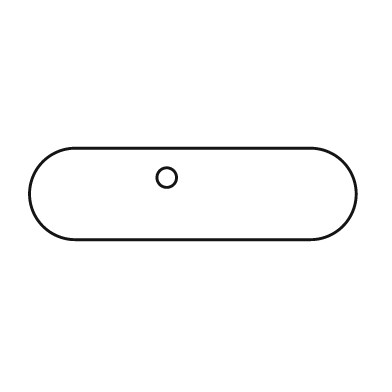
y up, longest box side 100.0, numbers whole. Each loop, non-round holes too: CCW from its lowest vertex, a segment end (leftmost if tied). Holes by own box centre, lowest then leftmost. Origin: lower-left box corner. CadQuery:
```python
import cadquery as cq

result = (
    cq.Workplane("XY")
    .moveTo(14.0, 0.0)
    .lineTo(86.0, 0.0)
    .threePointArc((100.0, 14.0), (86.0, 28.0))
    .lineTo(14.0, 28.0)
    .threePointArc((0.0, 14.0), (14.0, 0.0))
    .close()
    .moveTo(42.0, 19.0)
    .circle(3.0)
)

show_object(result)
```